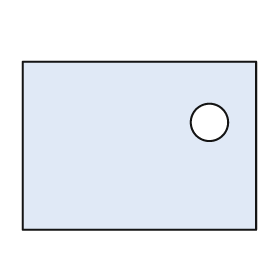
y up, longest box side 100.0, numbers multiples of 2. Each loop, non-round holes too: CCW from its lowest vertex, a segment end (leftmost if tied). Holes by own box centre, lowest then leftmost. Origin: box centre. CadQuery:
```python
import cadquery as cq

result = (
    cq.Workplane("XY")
    .moveTo(-50.0, -36.0)
    .lineTo(50.0, -36.0)
    .lineTo(50.0, 36.0)
    .lineTo(-50.0, 36.0)
    .close()
    .moveTo(30.0, 10.0)
    .circle(8.0)
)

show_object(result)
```